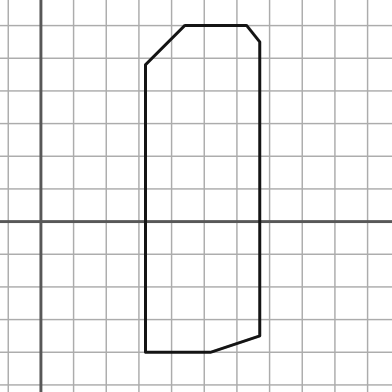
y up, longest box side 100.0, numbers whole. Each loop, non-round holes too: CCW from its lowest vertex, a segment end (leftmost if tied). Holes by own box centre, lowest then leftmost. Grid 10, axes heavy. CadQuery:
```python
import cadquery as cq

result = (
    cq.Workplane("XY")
    .moveTo(32.0, -40.0)
    .lineTo(52.0, -40.0)
    .lineTo(67.0, -35.0)
    .lineTo(67.0, 55.0)
    .lineTo(63.0, 60.0)
    .lineTo(44.0, 60.0)
    .lineTo(32.0, 48.0)
    .close()
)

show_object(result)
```